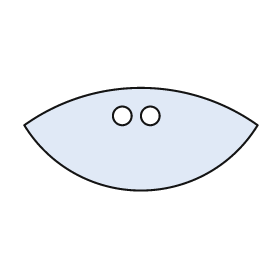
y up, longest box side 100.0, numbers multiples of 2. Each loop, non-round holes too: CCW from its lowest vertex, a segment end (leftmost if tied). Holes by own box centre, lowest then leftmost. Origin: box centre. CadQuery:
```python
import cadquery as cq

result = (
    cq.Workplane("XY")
    .moveTo(-50.0, 6.0)
    .threePointArc((0.0, -22.0), (50.0, 6.0))
    .threePointArc((0.0, 22.0), (-50.0, 6.0))
    .close()
    .moveTo(-8.0, 10.0)
    .circle(4.0)
    .moveTo(4.0, 10.0)
    .circle(4.0)
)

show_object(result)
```